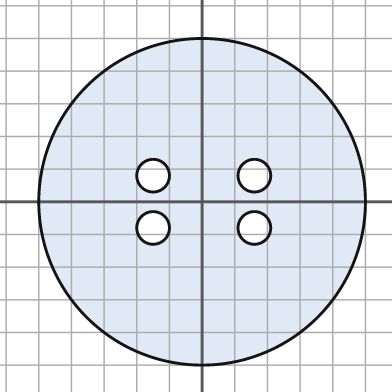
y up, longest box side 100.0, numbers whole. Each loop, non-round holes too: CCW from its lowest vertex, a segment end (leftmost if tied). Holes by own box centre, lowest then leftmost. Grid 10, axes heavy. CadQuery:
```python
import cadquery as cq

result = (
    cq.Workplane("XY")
    .moveTo(0.0, 0.0)
    .circle(50.0)
    .moveTo(-15.0, -8.0)
    .circle(5.0)
    .moveTo(16.0, -8.0)
    .circle(5.0)
    .moveTo(-15.0, 8.0)
    .circle(5.0)
    .moveTo(16.0, 8.0)
    .circle(5.0)
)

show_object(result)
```